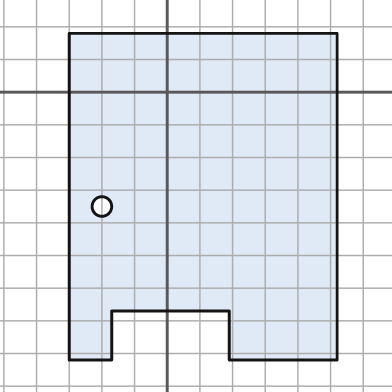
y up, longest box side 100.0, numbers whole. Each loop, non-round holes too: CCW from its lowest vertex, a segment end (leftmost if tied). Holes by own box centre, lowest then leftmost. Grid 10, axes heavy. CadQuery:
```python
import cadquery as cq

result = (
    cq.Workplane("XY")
    .moveTo(-30.0, -82.0)
    .lineTo(-17.0, -82.0)
    .lineTo(-17.0, -67.0)
    .lineTo(19.0, -67.0)
    .lineTo(19.0, -82.0)
    .lineTo(52.0, -82.0)
    .lineTo(52.0, 18.0)
    .lineTo(-30.0, 18.0)
    .close()
    .moveTo(-20.0, -35.0)
    .circle(3.0)
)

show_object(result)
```